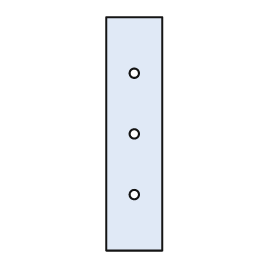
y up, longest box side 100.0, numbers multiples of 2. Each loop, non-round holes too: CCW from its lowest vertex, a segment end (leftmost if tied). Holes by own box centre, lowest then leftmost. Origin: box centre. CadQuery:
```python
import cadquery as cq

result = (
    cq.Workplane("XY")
    .moveTo(-12.0, -50.0)
    .lineTo(12.0, -50.0)
    .lineTo(12.0, 50.0)
    .lineTo(-12.0, 50.0)
    .close()
    .moveTo(0.0, -26.0)
    .circle(2.0)
    .moveTo(0.0, 0.0)
    .circle(2.0)
    .moveTo(0.0, 26.0)
    .circle(2.0)
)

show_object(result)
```